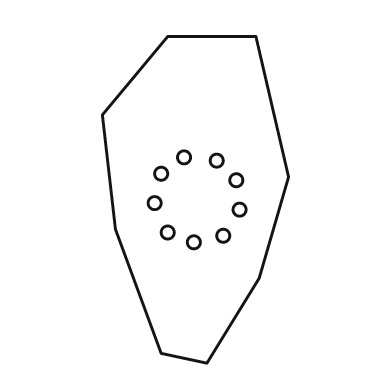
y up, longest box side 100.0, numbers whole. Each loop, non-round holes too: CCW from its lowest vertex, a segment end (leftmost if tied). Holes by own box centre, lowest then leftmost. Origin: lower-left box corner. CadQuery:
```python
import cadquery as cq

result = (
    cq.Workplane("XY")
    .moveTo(32.0, 0.0)
    .lineTo(48.0, 26.0)
    .lineTo(57.0, 57.0)
    .lineTo(47.0, 100.0)
    .lineTo(20.0, 100.0)
    .lineTo(0.0, 76.0)
    .lineTo(4.0, 41.0)
    .lineTo(18.0, 3.0)
    .close()
    .moveTo(28.0, 37.0)
    .circle(2.0)
    .moveTo(37.0, 39.0)
    .circle(2.0)
    .moveTo(20.0, 40.0)
    .circle(2.0)
    .moveTo(42.0, 47.0)
    .circle(2.0)
    .moveTo(16.0, 49.0)
    .circle(2.0)
    .moveTo(41.0, 56.0)
    .circle(2.0)
    .moveTo(18.0, 58.0)
    .circle(2.0)
    .moveTo(35.0, 62.0)
    .circle(2.0)
    .moveTo(25.0, 63.0)
    .circle(2.0)
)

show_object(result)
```